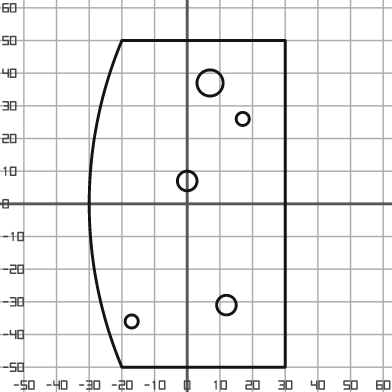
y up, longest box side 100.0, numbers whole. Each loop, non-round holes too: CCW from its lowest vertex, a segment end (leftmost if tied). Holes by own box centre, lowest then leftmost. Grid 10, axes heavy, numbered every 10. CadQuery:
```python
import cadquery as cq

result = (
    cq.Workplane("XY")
    .moveTo(-20.0, -50.0)
    .lineTo(30.0, -50.0)
    .lineTo(30.0, 50.0)
    .lineTo(-20.0, 50.0)
    .threePointArc((-30.0, 0.0), (-20.0, -50.0))
    .close()
    .moveTo(-17.0, -36.0)
    .circle(2.0)
    .moveTo(12.0, -31.0)
    .circle(3.0)
    .moveTo(0.0, 7.0)
    .circle(3.0)
    .moveTo(17.0, 26.0)
    .circle(2.0)
    .moveTo(7.0, 37.0)
    .circle(4.0)
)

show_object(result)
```